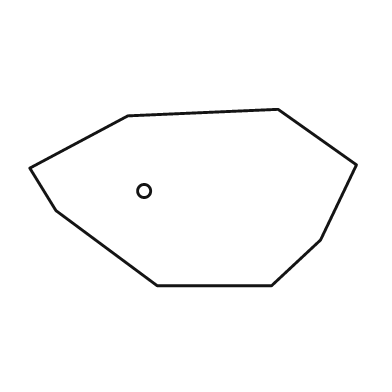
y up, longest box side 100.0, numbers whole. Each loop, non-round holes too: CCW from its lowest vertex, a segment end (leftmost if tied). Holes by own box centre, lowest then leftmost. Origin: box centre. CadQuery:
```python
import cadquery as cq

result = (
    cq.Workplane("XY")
    .moveTo(-11.0, -27.0)
    .lineTo(24.0, -27.0)
    .lineTo(39.0, -13.0)
    .lineTo(50.0, 10.0)
    .lineTo(26.0, 27.0)
    .lineTo(-20.0, 25.0)
    .lineTo(-50.0, 9.0)
    .lineTo(-42.0, -4.0)
    .close()
    .moveTo(-15.0, 2.0)
    .circle(2.0)
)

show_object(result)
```